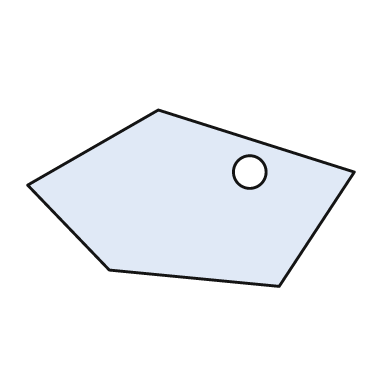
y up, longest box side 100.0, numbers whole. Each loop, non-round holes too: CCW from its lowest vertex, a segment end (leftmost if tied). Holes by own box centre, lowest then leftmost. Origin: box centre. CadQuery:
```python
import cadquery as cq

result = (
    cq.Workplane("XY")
    .moveTo(27.0, -27.0)
    .lineTo(50.0, 8.0)
    .lineTo(-10.0, 27.0)
    .lineTo(-50.0, 4.0)
    .lineTo(-25.0, -22.0)
    .close()
    .moveTo(18.0, 8.0)
    .circle(5.0)
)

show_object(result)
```